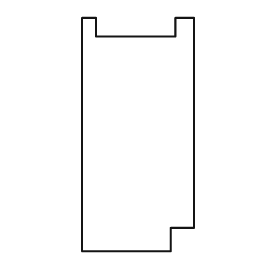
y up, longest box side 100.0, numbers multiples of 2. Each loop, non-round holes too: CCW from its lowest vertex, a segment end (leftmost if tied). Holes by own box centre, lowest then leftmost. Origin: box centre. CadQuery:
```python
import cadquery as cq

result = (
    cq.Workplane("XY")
    .moveTo(-24.0, -50.0)
    .lineTo(14.0, -50.0)
    .lineTo(14.0, -40.0)
    .lineTo(24.0, -40.0)
    .lineTo(24.0, 50.0)
    .lineTo(16.0, 50.0)
    .lineTo(16.0, 42.0)
    .lineTo(-18.0, 42.0)
    .lineTo(-18.0, 50.0)
    .lineTo(-24.0, 50.0)
    .close()
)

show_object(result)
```